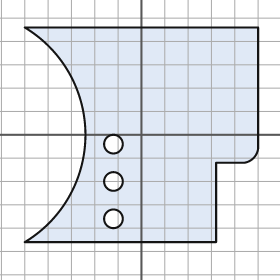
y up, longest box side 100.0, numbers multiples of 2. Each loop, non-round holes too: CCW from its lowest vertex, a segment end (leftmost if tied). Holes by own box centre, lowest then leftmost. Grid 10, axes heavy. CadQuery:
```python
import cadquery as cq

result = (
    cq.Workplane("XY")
    .moveTo(-50.0, -46.0)
    .lineTo(32.0, -46.0)
    .lineTo(32.0, -12.0)
    .lineTo(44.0, -12.0)
    .threePointArc((48.0, -10.0), (50.0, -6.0))
    .lineTo(50.0, 46.0)
    .lineTo(-50.0, 46.0)
    .threePointArc((-24.0, 0.0), (-50.0, -46.0))
    .close()
    .moveTo(-12.0, -36.0)
    .circle(4.0)
    .moveTo(-12.0, -20.0)
    .circle(4.0)
    .moveTo(-12.0, -4.0)
    .circle(4.0)
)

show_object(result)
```